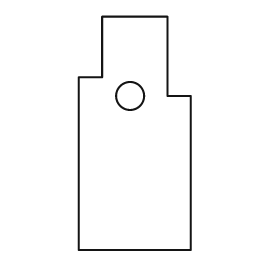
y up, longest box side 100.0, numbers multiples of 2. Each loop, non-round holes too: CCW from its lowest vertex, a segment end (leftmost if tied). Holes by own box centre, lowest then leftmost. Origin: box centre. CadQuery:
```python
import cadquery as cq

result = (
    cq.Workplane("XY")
    .moveTo(-24.0, -50.0)
    .lineTo(24.0, -50.0)
    .lineTo(24.0, 16.0)
    .lineTo(14.0, 16.0)
    .lineTo(14.0, 50.0)
    .lineTo(-14.0, 50.0)
    .lineTo(-14.0, 24.0)
    .lineTo(-24.0, 24.0)
    .close()
    .moveTo(-2.0, 16.0)
    .circle(6.0)
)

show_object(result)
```